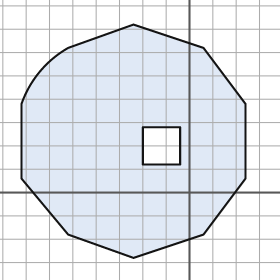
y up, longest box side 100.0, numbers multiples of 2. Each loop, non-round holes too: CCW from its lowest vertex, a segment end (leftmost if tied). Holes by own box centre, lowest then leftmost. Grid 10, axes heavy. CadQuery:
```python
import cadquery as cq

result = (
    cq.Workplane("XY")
    .moveTo(-24.0, -28.0)
    .lineTo(6.0, -18.0)
    .lineTo(24.0, 6.0)
    .lineTo(24.0, 38.0)
    .lineTo(6.0, 62.0)
    .lineTo(-24.0, 72.0)
    .lineTo(-52.0, 62.0)
    .threePointArc((-64.0, 52.0), (-72.0, 38.0))
    .lineTo(-72.0, 6.0)
    .lineTo(-52.0, -18.0)
    .close()
    .moveTo(-20.0, 12.0)
    .lineTo(-4.0, 12.0)
    .lineTo(-4.0, 28.0)
    .lineTo(-20.0, 28.0)
    .close()
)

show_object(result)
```